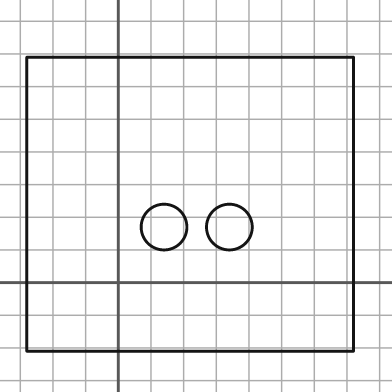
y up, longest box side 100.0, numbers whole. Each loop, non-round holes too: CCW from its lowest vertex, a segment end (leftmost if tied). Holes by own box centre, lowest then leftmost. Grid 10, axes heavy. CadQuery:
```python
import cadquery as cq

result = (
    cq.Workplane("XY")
    .moveTo(-28.0, -21.0)
    .lineTo(72.0, -21.0)
    .lineTo(72.0, 69.0)
    .lineTo(-28.0, 69.0)
    .close()
    .moveTo(14.0, 17.0)
    .circle(7.0)
    .moveTo(34.0, 17.0)
    .circle(7.0)
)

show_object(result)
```